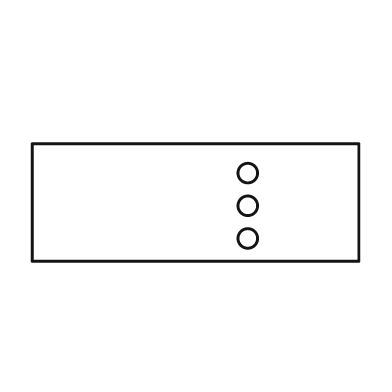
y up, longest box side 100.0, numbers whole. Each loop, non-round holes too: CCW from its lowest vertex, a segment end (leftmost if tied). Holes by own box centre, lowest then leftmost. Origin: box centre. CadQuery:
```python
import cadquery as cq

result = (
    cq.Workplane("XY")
    .moveTo(-50.0, -18.0)
    .lineTo(50.0, -18.0)
    .lineTo(50.0, 18.0)
    .lineTo(-50.0, 18.0)
    .close()
    .moveTo(16.0, -11.0)
    .circle(3.0)
    .moveTo(16.0, -1.0)
    .circle(3.0)
    .moveTo(16.0, 9.0)
    .circle(3.0)
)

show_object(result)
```